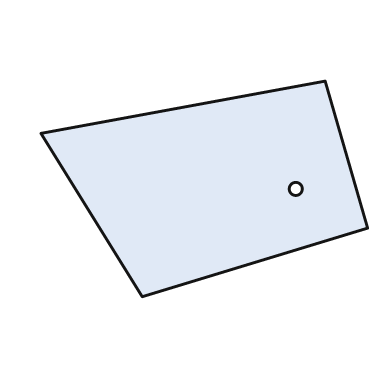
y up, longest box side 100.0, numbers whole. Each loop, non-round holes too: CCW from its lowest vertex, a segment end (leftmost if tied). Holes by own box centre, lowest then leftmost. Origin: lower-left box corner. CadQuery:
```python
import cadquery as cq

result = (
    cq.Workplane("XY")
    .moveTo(31.0, 0.0)
    .lineTo(100.0, 21.0)
    .lineTo(87.0, 66.0)
    .lineTo(0.0, 50.0)
    .close()
    .moveTo(78.0, 33.0)
    .circle(2.0)
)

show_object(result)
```